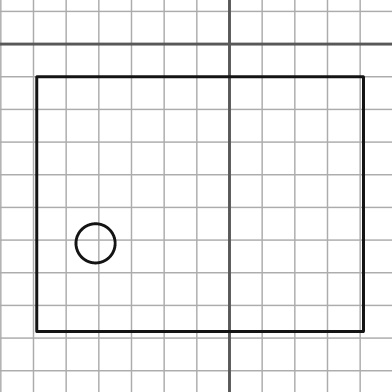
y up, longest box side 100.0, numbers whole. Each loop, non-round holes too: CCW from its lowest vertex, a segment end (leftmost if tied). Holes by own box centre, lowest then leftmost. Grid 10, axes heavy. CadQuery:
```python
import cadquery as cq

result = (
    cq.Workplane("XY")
    .moveTo(-59.0, -88.0)
    .lineTo(41.0, -88.0)
    .lineTo(41.0, -10.0)
    .lineTo(-59.0, -10.0)
    .close()
    .moveTo(-41.0, -61.0)
    .circle(6.0)
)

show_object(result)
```